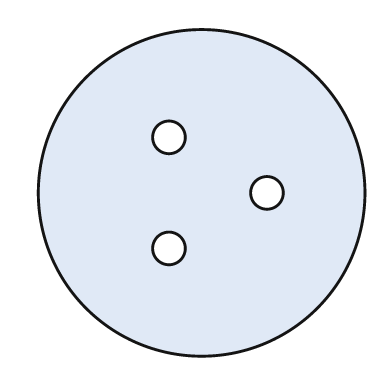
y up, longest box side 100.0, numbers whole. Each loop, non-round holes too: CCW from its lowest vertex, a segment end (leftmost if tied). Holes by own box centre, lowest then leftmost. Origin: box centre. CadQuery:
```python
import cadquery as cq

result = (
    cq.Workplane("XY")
    .moveTo(0.0, 0.0)
    .circle(50.0)
    .moveTo(-10.0, -17.0)
    .circle(5.0)
    .moveTo(20.0, 0.0)
    .circle(5.0)
    .moveTo(-10.0, 17.0)
    .circle(5.0)
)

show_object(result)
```